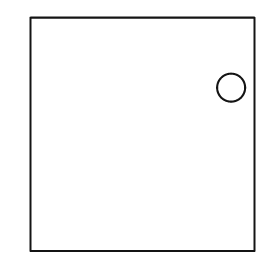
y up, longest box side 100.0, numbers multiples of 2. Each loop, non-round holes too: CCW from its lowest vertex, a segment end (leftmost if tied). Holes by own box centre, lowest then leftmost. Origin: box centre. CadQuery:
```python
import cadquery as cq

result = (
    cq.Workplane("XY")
    .moveTo(-48.0, -50.0)
    .lineTo(48.0, -50.0)
    .lineTo(48.0, 50.0)
    .lineTo(-48.0, 50.0)
    .close()
    .moveTo(38.0, 20.0)
    .circle(6.0)
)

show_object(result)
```